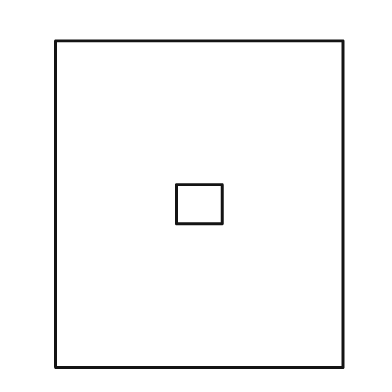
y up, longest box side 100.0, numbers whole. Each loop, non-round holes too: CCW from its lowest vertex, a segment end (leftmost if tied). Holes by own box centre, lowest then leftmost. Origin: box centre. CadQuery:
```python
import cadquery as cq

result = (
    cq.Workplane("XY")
    .moveTo(-44.0, -50.0)
    .lineTo(44.0, -50.0)
    .lineTo(44.0, 50.0)
    .lineTo(-44.0, 50.0)
    .close()
    .moveTo(-7.0, -6.0)
    .lineTo(7.0, -6.0)
    .lineTo(7.0, 6.0)
    .lineTo(-7.0, 6.0)
    .close()
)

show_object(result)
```